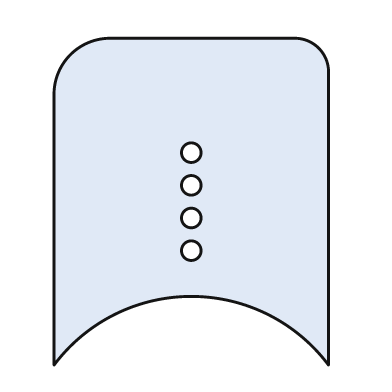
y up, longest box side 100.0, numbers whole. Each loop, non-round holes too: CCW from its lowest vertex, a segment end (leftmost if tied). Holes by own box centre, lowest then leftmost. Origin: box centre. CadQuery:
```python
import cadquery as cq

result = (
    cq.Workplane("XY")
    .moveTo(-42.0, -50.0)
    .threePointArc((0.0, -29.0), (42.0, -50.0))
    .lineTo(42.0, 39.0)
    .threePointArc((39.0, 47.0), (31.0, 50.0))
    .lineTo(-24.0, 50.0)
    .threePointArc((-37.0, 45.0), (-42.0, 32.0))
    .close()
    .moveTo(0.0, -15.0)
    .circle(3.0)
    .moveTo(0.0, -5.0)
    .circle(3.0)
    .moveTo(0.0, 5.0)
    .circle(3.0)
    .moveTo(0.0, 15.0)
    .circle(3.0)
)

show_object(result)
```